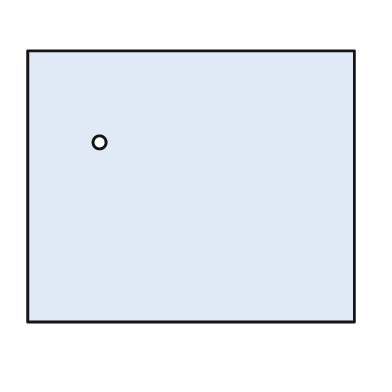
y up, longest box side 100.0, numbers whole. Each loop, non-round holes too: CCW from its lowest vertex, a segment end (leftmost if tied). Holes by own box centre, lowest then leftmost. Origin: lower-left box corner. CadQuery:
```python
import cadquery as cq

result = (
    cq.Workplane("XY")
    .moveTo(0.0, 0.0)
    .lineTo(100.0, 0.0)
    .lineTo(100.0, 83.0)
    .lineTo(0.0, 83.0)
    .close()
    .moveTo(22.0, 55.0)
    .circle(2.0)
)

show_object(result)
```